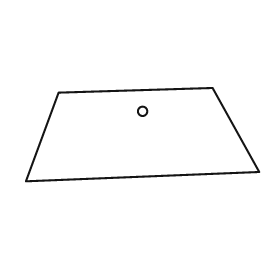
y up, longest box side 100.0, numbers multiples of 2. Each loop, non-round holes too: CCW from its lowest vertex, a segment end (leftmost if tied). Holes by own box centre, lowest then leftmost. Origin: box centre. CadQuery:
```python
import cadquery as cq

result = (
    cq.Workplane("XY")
    .moveTo(-50.0, -20.0)
    .lineTo(50.0, -16.0)
    .lineTo(30.0, 20.0)
    .lineTo(-36.0, 18.0)
    .close()
    .moveTo(0.0, 10.0)
    .circle(2.0)
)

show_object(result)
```